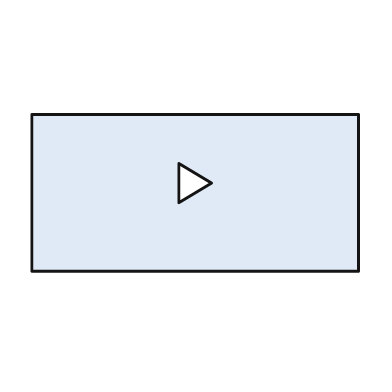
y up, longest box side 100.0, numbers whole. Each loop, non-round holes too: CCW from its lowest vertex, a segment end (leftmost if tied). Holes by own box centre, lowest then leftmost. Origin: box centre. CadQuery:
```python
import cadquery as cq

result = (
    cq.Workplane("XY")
    .moveTo(-50.0, -24.0)
    .lineTo(50.0, -24.0)
    .lineTo(50.0, 24.0)
    .lineTo(-50.0, 24.0)
    .close()
    .moveTo(-5.0, -3.0)
    .lineTo(5.0, 3.0)
    .lineTo(-5.0, 9.0)
    .close()
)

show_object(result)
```